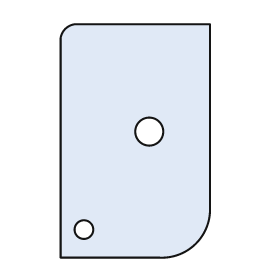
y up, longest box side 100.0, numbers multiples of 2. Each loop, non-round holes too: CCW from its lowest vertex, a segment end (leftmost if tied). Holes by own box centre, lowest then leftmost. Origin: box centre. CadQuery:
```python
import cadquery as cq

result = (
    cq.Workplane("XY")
    .moveTo(-32.0, -50.0)
    .lineTo(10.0, -50.0)
    .threePointArc((26.0, -44.0), (32.0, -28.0))
    .lineTo(32.0, 50.0)
    .lineTo(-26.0, 50.0)
    .threePointArc((-30.0, 48.0), (-32.0, 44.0))
    .close()
    .moveTo(-22.0, -38.0)
    .circle(4.0)
    .moveTo(6.0, 4.0)
    .circle(6.0)
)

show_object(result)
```